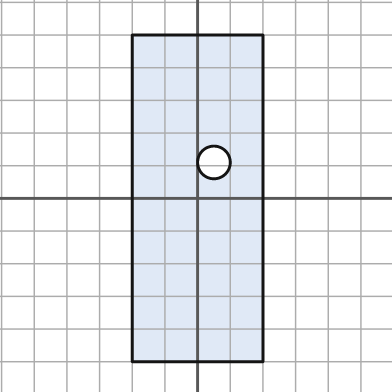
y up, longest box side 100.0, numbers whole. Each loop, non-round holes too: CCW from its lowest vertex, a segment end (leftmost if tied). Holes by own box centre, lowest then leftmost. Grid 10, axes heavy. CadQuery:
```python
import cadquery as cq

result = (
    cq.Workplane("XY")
    .moveTo(-20.0, -50.0)
    .lineTo(20.0, -50.0)
    .lineTo(20.0, 50.0)
    .lineTo(-20.0, 50.0)
    .close()
    .moveTo(5.0, 11.0)
    .circle(5.0)
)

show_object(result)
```